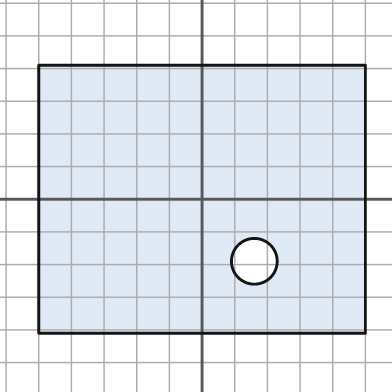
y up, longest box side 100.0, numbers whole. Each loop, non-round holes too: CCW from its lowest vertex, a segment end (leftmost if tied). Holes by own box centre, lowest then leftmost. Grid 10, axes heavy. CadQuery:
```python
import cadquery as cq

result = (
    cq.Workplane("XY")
    .moveTo(-50.0, -41.0)
    .lineTo(50.0, -41.0)
    .lineTo(50.0, 41.0)
    .lineTo(-50.0, 41.0)
    .close()
    .moveTo(16.0, -19.0)
    .circle(7.0)
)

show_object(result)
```